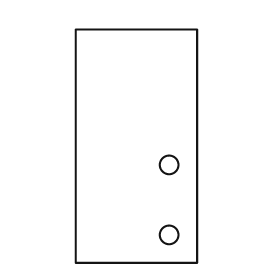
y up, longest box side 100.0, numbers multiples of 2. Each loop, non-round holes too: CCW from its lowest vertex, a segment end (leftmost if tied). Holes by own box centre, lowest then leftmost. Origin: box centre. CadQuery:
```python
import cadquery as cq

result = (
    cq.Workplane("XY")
    .moveTo(-26.0, -50.0)
    .lineTo(26.0, -50.0)
    .lineTo(26.0, 50.0)
    .lineTo(-26.0, 50.0)
    .close()
    .moveTo(14.0, -38.0)
    .circle(4.0)
    .moveTo(14.0, -8.0)
    .circle(4.0)
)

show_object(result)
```